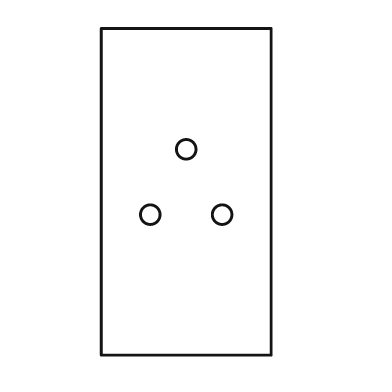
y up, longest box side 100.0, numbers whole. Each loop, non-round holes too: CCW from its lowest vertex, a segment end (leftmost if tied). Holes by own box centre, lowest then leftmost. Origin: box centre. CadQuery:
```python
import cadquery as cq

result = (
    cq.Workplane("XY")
    .moveTo(-26.0, -50.0)
    .lineTo(26.0, -50.0)
    .lineTo(26.0, 50.0)
    .lineTo(-26.0, 50.0)
    .close()
    .moveTo(-11.0, -7.0)
    .circle(3.0)
    .moveTo(11.0, -7.0)
    .circle(3.0)
    .moveTo(0.0, 13.0)
    .circle(3.0)
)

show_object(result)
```